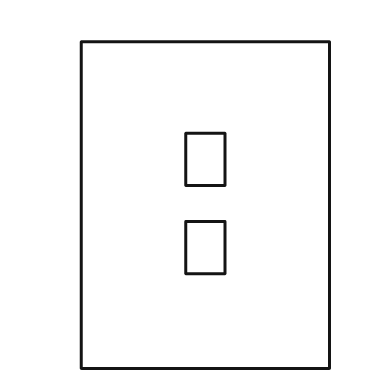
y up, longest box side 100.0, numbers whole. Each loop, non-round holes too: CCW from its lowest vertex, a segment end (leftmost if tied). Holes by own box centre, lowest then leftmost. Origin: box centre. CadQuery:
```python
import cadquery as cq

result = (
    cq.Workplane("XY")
    .moveTo(-38.0, -50.0)
    .lineTo(38.0, -50.0)
    .lineTo(38.0, 50.0)
    .lineTo(-38.0, 50.0)
    .close()
    .moveTo(-6.0, -21.0)
    .lineTo(6.0, -21.0)
    .lineTo(6.0, -5.0)
    .lineTo(-6.0, -5.0)
    .close()
    .moveTo(-6.0, 6.0)
    .lineTo(6.0, 6.0)
    .lineTo(6.0, 22.0)
    .lineTo(-6.0, 22.0)
    .close()
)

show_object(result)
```